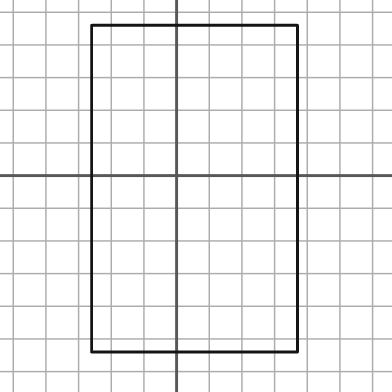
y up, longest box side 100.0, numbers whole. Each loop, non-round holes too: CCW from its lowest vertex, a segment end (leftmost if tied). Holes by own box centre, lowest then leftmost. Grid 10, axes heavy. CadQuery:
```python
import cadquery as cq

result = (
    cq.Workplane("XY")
    .moveTo(-26.0, -54.0)
    .lineTo(37.0, -54.0)
    .lineTo(37.0, 46.0)
    .lineTo(-26.0, 46.0)
    .close()
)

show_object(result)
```